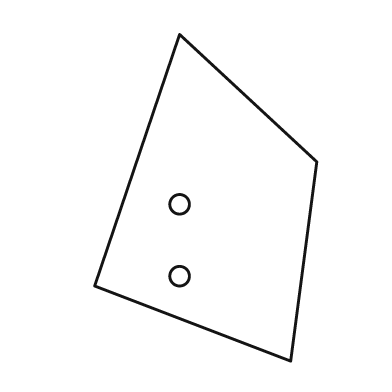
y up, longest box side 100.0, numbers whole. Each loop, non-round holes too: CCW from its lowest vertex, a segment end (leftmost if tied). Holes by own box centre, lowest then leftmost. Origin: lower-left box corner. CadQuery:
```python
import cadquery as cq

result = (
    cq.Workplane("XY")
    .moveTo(60.0, 0.0)
    .lineTo(68.0, 61.0)
    .lineTo(26.0, 100.0)
    .lineTo(0.0, 23.0)
    .close()
    .moveTo(26.0, 26.0)
    .circle(3.0)
    .moveTo(26.0, 48.0)
    .circle(3.0)
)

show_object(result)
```